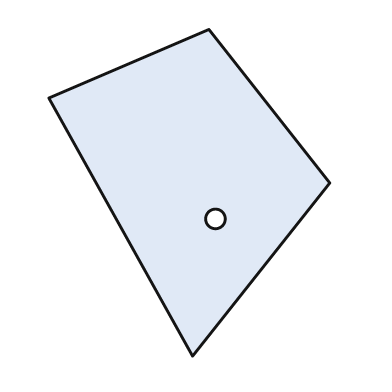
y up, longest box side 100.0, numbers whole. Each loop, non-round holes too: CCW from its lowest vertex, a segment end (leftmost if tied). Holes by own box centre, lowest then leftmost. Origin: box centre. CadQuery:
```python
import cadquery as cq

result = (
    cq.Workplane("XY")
    .moveTo(1.0, -50.0)
    .lineTo(43.0, 3.0)
    .lineTo(6.0, 50.0)
    .lineTo(-43.0, 29.0)
    .close()
    .moveTo(8.0, -8.0)
    .circle(3.0)
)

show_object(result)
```